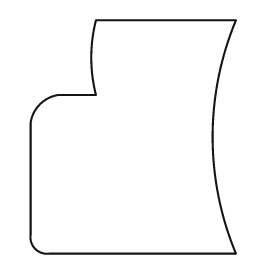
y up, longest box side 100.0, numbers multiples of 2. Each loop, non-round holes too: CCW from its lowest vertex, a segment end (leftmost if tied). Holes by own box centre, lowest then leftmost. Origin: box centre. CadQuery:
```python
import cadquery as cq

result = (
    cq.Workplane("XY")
    .moveTo(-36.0, -50.0)
    .lineTo(44.0, -50.0)
    .threePointArc((34.0, 0.0), (44.0, 50.0))
    .lineTo(-16.0, 50.0)
    .threePointArc((-18.0, 34.0), (-16.0, 18.0))
    .lineTo(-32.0, 18.0)
    .threePointArc((-40.0, 14.0), (-44.0, 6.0))
    .lineTo(-44.0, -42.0)
    .threePointArc((-42.0, -48.0), (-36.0, -50.0))
    .close()
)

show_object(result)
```